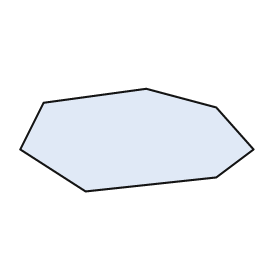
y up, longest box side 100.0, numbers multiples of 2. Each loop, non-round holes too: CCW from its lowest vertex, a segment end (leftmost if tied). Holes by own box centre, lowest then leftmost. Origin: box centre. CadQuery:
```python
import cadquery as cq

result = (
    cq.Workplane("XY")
    .moveTo(-22.0, -22.0)
    .lineTo(34.0, -16.0)
    .lineTo(50.0, -4.0)
    .lineTo(34.0, 14.0)
    .lineTo(4.0, 22.0)
    .lineTo(-40.0, 16.0)
    .lineTo(-50.0, -4.0)
    .close()
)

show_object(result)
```